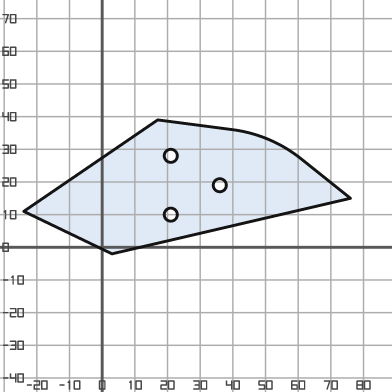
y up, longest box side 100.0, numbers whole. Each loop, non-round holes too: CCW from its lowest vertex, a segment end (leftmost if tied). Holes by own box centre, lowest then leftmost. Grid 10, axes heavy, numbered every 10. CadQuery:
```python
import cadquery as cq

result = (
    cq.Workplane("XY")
    .moveTo(3.0, -2.0)
    .lineTo(76.0, 15.0)
    .lineTo(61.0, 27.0)
    .threePointArc((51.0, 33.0), (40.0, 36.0))
    .lineTo(17.0, 39.0)
    .lineTo(-24.0, 11.0)
    .close()
    .moveTo(21.0, 10.0)
    .circle(2.0)
    .moveTo(36.0, 19.0)
    .circle(2.0)
    .moveTo(21.0, 28.0)
    .circle(2.0)
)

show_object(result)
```